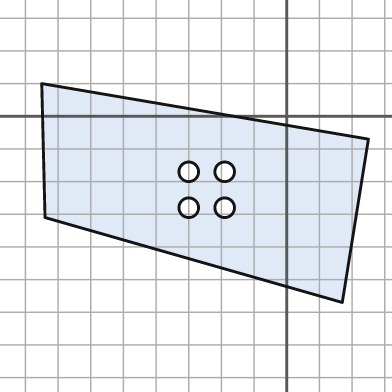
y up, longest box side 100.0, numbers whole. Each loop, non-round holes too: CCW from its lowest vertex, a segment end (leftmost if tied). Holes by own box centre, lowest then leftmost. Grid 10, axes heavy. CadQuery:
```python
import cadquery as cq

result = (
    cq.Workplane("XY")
    .moveTo(17.0, -57.0)
    .lineTo(25.0, -7.0)
    .lineTo(-75.0, 10.0)
    .lineTo(-74.0, -31.0)
    .close()
    .moveTo(-30.0, -28.0)
    .circle(3.0)
    .moveTo(-19.0, -28.0)
    .circle(3.0)
    .moveTo(-30.0, -17.0)
    .circle(3.0)
    .moveTo(-19.0, -17.0)
    .circle(3.0)
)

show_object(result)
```